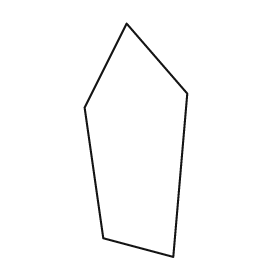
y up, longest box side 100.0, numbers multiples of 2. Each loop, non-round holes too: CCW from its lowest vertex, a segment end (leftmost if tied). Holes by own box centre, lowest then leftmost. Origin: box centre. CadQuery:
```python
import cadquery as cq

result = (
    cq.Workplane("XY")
    .moveTo(16.0, -50.0)
    .lineTo(22.0, 20.0)
    .lineTo(-4.0, 50.0)
    .lineTo(-22.0, 14.0)
    .lineTo(-14.0, -42.0)
    .close()
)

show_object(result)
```